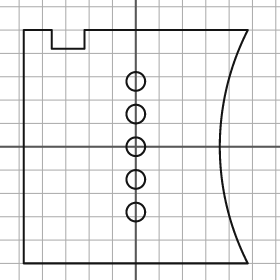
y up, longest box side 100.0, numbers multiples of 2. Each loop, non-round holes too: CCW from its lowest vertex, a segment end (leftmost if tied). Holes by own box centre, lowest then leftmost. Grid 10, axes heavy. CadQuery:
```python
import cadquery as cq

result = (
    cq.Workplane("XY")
    .moveTo(-48.0, -50.0)
    .lineTo(48.0, -50.0)
    .threePointArc((36.0, 0.0), (48.0, 50.0))
    .lineTo(-22.0, 50.0)
    .lineTo(-22.0, 42.0)
    .lineTo(-36.0, 42.0)
    .lineTo(-36.0, 50.0)
    .lineTo(-48.0, 50.0)
    .close()
    .moveTo(0.0, -28.0)
    .circle(4.0)
    .moveTo(0.0, -14.0)
    .circle(4.0)
    .moveTo(0.0, 0.0)
    .circle(4.0)
    .moveTo(0.0, 14.0)
    .circle(4.0)
    .moveTo(0.0, 28.0)
    .circle(4.0)
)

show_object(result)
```